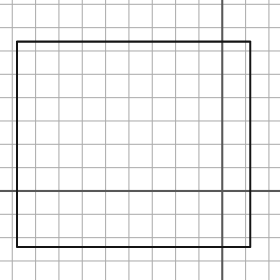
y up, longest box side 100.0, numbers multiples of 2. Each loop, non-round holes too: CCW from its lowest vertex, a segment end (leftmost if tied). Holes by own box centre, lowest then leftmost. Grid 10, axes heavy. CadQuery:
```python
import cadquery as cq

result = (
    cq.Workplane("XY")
    .moveTo(-88.0, -24.0)
    .lineTo(12.0, -24.0)
    .lineTo(12.0, 64.0)
    .lineTo(-88.0, 64.0)
    .close()
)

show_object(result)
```